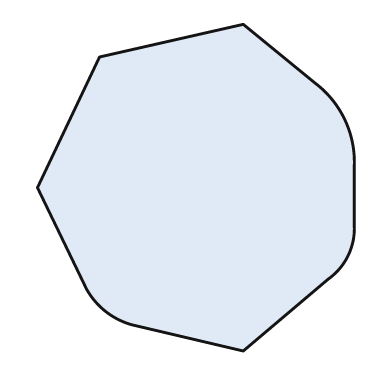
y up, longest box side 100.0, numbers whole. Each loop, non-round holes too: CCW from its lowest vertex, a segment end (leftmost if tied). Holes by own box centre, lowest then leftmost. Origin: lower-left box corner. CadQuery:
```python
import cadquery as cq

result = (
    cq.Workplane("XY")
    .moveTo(63.0, 0.0)
    .lineTo(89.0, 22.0)
    .threePointArc((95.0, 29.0), (97.0, 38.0))
    .lineTo(97.0, 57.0)
    .threePointArc((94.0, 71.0), (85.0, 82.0))
    .lineTo(63.0, 100.0)
    .lineTo(19.0, 90.0)
    .lineTo(0.0, 50.0)
    .lineTo(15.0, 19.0)
    .threePointArc((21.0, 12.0), (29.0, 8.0))
    .close()
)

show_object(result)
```